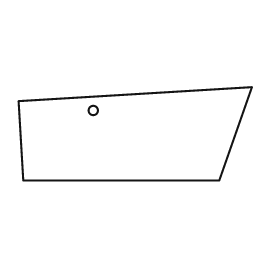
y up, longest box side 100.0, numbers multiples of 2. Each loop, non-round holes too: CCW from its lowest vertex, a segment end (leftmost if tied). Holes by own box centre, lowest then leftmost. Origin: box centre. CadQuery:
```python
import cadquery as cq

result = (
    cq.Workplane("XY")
    .moveTo(-48.0, -20.0)
    .lineTo(36.0, -20.0)
    .lineTo(50.0, 20.0)
    .lineTo(-50.0, 14.0)
    .close()
    .moveTo(-18.0, 10.0)
    .circle(2.0)
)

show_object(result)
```